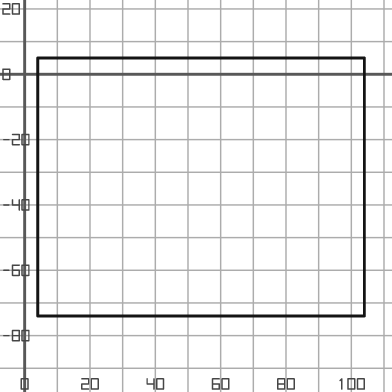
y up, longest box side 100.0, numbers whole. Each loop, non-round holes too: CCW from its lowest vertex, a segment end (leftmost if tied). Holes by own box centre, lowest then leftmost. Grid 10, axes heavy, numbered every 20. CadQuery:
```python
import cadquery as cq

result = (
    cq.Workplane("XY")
    .moveTo(4.0, -74.0)
    .lineTo(104.0, -74.0)
    .lineTo(104.0, 5.0)
    .lineTo(4.0, 5.0)
    .close()
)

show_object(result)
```